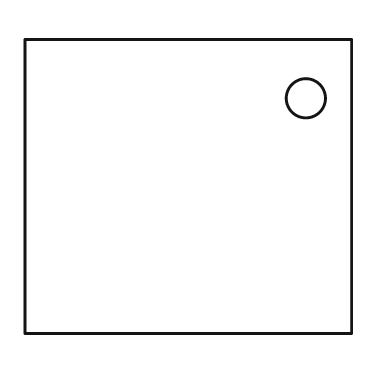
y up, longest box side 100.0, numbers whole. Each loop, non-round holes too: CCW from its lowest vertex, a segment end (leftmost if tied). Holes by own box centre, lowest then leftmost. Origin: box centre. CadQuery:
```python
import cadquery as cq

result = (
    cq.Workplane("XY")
    .moveTo(-50.0, -45.0)
    .lineTo(50.0, -45.0)
    .lineTo(50.0, 45.0)
    .lineTo(-50.0, 45.0)
    .close()
    .moveTo(36.0, 27.0)
    .circle(6.0)
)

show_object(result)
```